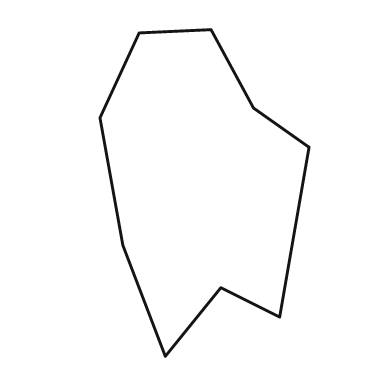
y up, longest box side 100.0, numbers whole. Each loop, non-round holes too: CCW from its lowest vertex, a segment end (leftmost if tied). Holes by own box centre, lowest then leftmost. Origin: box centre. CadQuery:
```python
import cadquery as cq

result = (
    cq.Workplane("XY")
    .moveTo(-12.0, -50.0)
    .lineTo(5.0, -29.0)
    .lineTo(23.0, -38.0)
    .lineTo(32.0, 14.0)
    .lineTo(15.0, 26.0)
    .lineTo(2.0, 50.0)
    .lineTo(-20.0, 49.0)
    .lineTo(-32.0, 23.0)
    .lineTo(-25.0, -16.0)
    .close()
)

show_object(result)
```